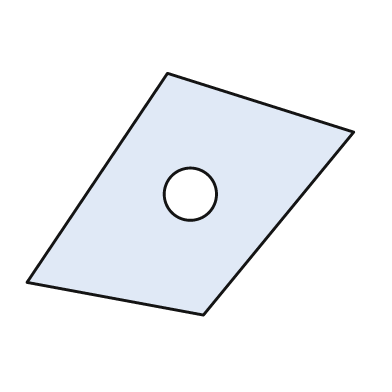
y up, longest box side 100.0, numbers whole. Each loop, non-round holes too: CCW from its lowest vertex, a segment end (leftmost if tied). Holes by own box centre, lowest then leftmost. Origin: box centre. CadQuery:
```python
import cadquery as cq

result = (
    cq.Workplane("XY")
    .moveTo(4.0, -37.0)
    .lineTo(50.0, 19.0)
    .lineTo(-7.0, 37.0)
    .lineTo(-50.0, -27.0)
    .close()
    .moveTo(0.0, 0.0)
    .circle(8.0)
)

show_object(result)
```